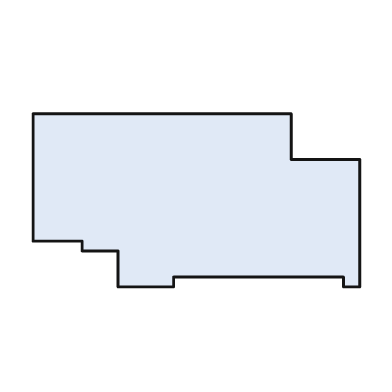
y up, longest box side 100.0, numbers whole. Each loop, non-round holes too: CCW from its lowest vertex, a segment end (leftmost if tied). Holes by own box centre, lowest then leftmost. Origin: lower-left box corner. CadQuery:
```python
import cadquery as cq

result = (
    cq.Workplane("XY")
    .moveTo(26.0, 0.0)
    .lineTo(43.0, 0.0)
    .lineTo(43.0, 3.0)
    .lineTo(95.0, 3.0)
    .lineTo(95.0, 0.0)
    .lineTo(100.0, 0.0)
    .lineTo(100.0, 39.0)
    .lineTo(79.0, 39.0)
    .lineTo(79.0, 53.0)
    .lineTo(0.0, 53.0)
    .lineTo(0.0, 14.0)
    .lineTo(15.0, 14.0)
    .lineTo(15.0, 11.0)
    .lineTo(26.0, 11.0)
    .close()
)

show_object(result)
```